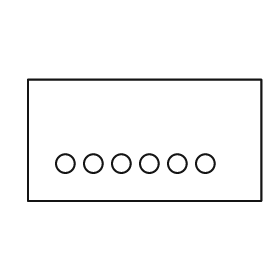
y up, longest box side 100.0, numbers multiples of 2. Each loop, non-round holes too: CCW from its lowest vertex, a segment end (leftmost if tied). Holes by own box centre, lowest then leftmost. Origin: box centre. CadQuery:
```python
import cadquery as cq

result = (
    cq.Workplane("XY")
    .moveTo(-50.0, -26.0)
    .lineTo(50.0, -26.0)
    .lineTo(50.0, 26.0)
    .lineTo(-50.0, 26.0)
    .close()
    .moveTo(-34.0, -10.0)
    .circle(4.0)
    .moveTo(-22.0, -10.0)
    .circle(4.0)
    .moveTo(-10.0, -10.0)
    .circle(4.0)
    .moveTo(2.0, -10.0)
    .circle(4.0)
    .moveTo(14.0, -10.0)
    .circle(4.0)
    .moveTo(26.0, -10.0)
    .circle(4.0)
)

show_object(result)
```